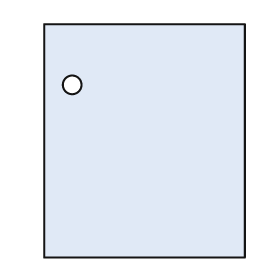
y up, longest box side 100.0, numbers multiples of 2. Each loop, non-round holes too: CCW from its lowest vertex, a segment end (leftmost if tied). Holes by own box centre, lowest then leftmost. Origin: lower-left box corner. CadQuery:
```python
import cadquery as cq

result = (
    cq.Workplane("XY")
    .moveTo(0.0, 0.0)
    .lineTo(86.0, 0.0)
    .lineTo(86.0, 100.0)
    .lineTo(0.0, 100.0)
    .close()
    .moveTo(12.0, 74.0)
    .circle(4.0)
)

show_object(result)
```